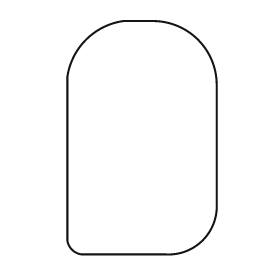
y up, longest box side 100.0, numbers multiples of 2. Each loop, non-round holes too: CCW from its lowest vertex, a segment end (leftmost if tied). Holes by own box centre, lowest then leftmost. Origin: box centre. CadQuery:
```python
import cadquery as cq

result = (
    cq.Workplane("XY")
    .moveTo(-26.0, -50.0)
    .lineTo(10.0, -50.0)
    .threePointArc((26.0, -44.0), (32.0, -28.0))
    .lineTo(32.0, 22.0)
    .threePointArc((24.0, 42.0), (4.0, 50.0))
    .lineTo(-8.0, 50.0)
    .threePointArc((-24.0, 42.0), (-32.0, 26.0))
    .lineTo(-32.0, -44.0)
    .threePointArc((-30.0, -48.0), (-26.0, -50.0))
    .close()
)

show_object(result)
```